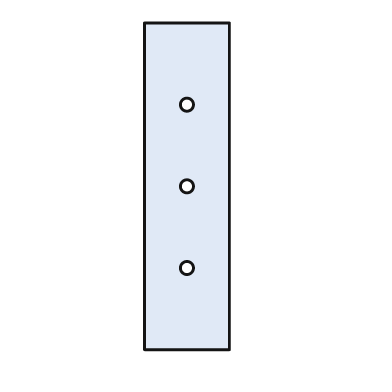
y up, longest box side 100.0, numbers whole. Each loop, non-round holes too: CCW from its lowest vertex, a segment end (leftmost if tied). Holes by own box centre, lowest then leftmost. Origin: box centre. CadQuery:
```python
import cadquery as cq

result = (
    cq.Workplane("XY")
    .moveTo(-13.0, -50.0)
    .lineTo(13.0, -50.0)
    .lineTo(13.0, 50.0)
    .lineTo(-13.0, 50.0)
    .close()
    .moveTo(0.0, -25.0)
    .circle(2.0)
    .moveTo(0.0, 0.0)
    .circle(2.0)
    .moveTo(0.0, 25.0)
    .circle(2.0)
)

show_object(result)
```